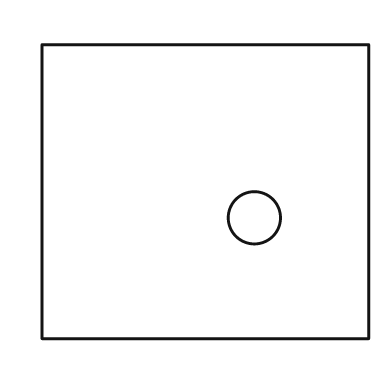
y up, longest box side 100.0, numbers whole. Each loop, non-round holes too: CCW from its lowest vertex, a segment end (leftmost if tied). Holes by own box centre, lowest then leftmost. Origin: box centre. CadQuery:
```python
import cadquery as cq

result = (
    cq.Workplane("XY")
    .moveTo(-50.0, -45.0)
    .lineTo(50.0, -45.0)
    .lineTo(50.0, 45.0)
    .lineTo(-50.0, 45.0)
    .close()
    .moveTo(15.0, -8.0)
    .circle(8.0)
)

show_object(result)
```